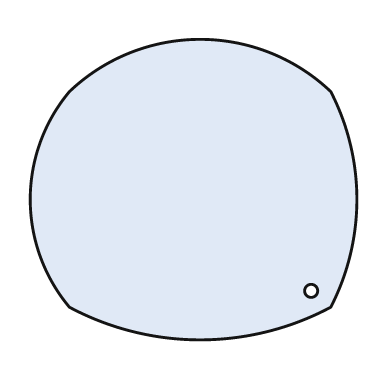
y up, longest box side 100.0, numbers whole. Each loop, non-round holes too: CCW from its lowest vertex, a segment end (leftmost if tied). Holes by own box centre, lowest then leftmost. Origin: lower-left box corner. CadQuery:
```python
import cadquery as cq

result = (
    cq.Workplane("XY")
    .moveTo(12.0, 10.0)
    .threePointArc((52.0, 0.0), (92.0, 10.0))
    .threePointArc((100.0, 43.0), (92.0, 76.0))
    .threePointArc((52.0, 92.0), (12.0, 76.0))
    .threePointArc((0.0, 43.0), (12.0, 10.0))
    .close()
    .moveTo(86.0, 15.0)
    .circle(2.0)
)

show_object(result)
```